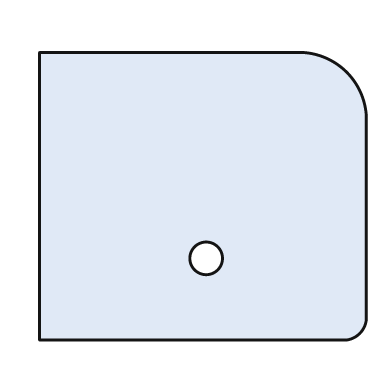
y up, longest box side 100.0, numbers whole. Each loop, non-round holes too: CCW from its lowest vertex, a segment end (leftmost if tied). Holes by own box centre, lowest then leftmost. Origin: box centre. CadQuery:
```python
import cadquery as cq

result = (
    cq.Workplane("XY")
    .moveTo(-50.0, -44.0)
    .lineTo(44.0, -44.0)
    .threePointArc((48.0, -42.0), (50.0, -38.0))
    .lineTo(50.0, 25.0)
    .threePointArc((44.0, 38.0), (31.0, 44.0))
    .lineTo(-50.0, 44.0)
    .close()
    .moveTo(1.0, -19.0)
    .circle(5.0)
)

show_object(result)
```